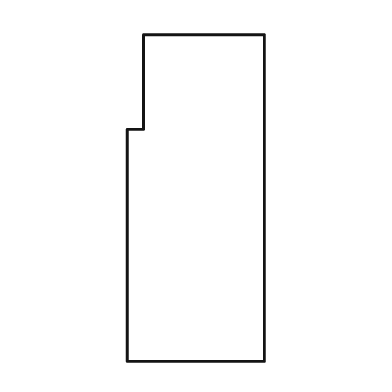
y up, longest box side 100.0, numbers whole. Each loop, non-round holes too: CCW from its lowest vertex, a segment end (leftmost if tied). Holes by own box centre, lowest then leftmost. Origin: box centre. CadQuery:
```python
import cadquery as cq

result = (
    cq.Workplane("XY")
    .moveTo(-21.0, -50.0)
    .lineTo(21.0, -50.0)
    .lineTo(21.0, 50.0)
    .lineTo(-16.0, 50.0)
    .lineTo(-16.0, 21.0)
    .lineTo(-21.0, 21.0)
    .close()
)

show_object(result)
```